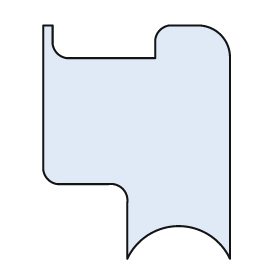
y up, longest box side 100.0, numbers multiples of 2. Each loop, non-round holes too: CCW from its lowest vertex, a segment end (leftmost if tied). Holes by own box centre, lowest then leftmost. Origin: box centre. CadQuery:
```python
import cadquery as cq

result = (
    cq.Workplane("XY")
    .moveTo(-4.0, -50.0)
    .threePointArc((18.0, -36.0), (40.0, -50.0))
    .lineTo(40.0, 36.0)
    .threePointArc((36.0, 46.0), (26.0, 50.0))
    .lineTo(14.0, 50.0)
    .threePointArc((10.0, 48.0), (8.0, 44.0))
    .lineTo(8.0, 36.0)
    .lineTo(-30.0, 36.0)
    .threePointArc((-34.0, 38.0), (-36.0, 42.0))
    .lineTo(-36.0, 50.0)
    .lineTo(-40.0, 50.0)
    .lineTo(-40.0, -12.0)
    .threePointArc((-38.0, -16.0), (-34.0, -18.0))
    .lineTo(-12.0, -18.0)
    .threePointArc((-6.0, -20.0), (-4.0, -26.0))
    .close()
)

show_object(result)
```